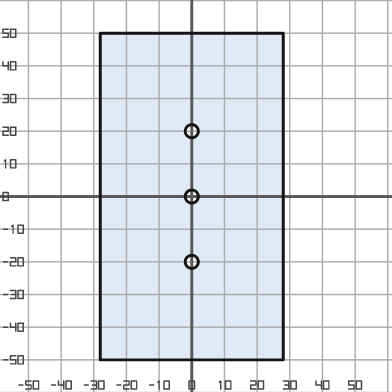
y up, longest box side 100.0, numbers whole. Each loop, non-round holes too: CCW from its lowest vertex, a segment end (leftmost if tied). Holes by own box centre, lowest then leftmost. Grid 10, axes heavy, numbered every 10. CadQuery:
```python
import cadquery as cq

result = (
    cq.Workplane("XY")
    .moveTo(-28.0, -50.0)
    .lineTo(28.0, -50.0)
    .lineTo(28.0, 50.0)
    .lineTo(-28.0, 50.0)
    .close()
    .moveTo(0.0, -20.0)
    .circle(2.0)
    .moveTo(0.0, 0.0)
    .circle(2.0)
    .moveTo(0.0, 20.0)
    .circle(2.0)
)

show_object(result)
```